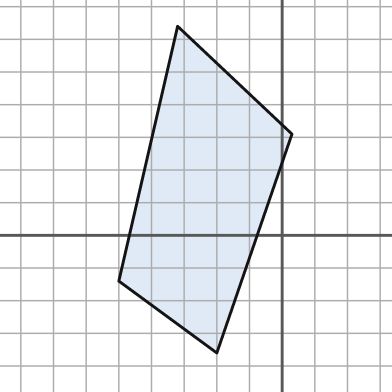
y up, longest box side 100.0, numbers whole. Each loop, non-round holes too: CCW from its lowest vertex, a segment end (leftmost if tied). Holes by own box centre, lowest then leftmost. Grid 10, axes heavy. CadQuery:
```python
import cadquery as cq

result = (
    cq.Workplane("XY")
    .moveTo(-20.0, -36.0)
    .lineTo(3.0, 31.0)
    .lineTo(-32.0, 64.0)
    .lineTo(-50.0, -14.0)
    .close()
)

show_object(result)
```